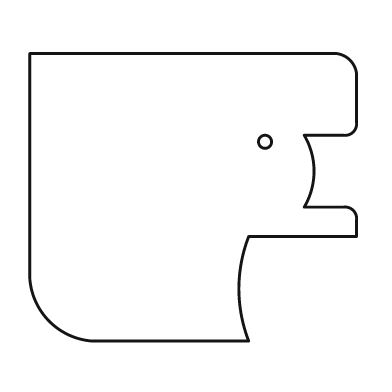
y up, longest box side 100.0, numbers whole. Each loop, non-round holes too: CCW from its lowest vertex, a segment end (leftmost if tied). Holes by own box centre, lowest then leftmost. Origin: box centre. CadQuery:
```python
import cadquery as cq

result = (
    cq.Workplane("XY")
    .moveTo(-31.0, -44.0)
    .lineTo(17.0, -44.0)
    .threePointArc((14.0, -28.0), (17.0, -12.0))
    .lineTo(50.0, -12.0)
    .lineTo(50.0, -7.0)
    .threePointArc((49.0, -4.0), (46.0, -3.0))
    .lineTo(34.0, -3.0)
    .threePointArc((37.0, 8.0), (34.0, 19.0))
    .lineTo(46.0, 19.0)
    .threePointArc((49.0, 20.0), (50.0, 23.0))
    .lineTo(50.0, 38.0)
    .threePointArc((48.0, 42.0), (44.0, 44.0))
    .lineTo(-50.0, 44.0)
    .lineTo(-50.0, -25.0)
    .threePointArc((-44.0, -38.0), (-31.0, -44.0))
    .close()
    .moveTo(22.0, 17.0)
    .circle(2.0)
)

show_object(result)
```